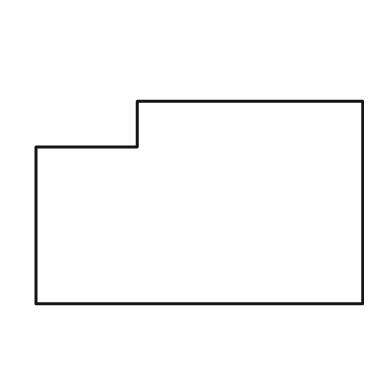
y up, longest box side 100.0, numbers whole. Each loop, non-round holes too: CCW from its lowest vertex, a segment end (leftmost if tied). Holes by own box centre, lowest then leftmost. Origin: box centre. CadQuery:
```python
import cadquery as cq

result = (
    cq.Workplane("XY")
    .moveTo(-50.0, -31.0)
    .lineTo(50.0, -31.0)
    .lineTo(50.0, 31.0)
    .lineTo(-19.0, 31.0)
    .lineTo(-19.0, 17.0)
    .lineTo(-50.0, 17.0)
    .close()
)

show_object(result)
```